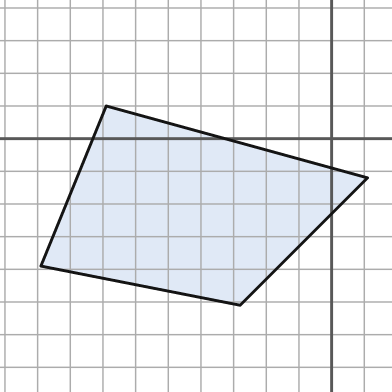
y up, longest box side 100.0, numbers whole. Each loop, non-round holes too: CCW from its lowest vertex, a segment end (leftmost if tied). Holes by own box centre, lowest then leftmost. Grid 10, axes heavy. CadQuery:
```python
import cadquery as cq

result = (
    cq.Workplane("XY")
    .moveTo(-28.0, -51.0)
    .lineTo(11.0, -12.0)
    .lineTo(-69.0, 10.0)
    .lineTo(-89.0, -39.0)
    .close()
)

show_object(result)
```